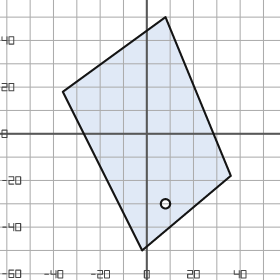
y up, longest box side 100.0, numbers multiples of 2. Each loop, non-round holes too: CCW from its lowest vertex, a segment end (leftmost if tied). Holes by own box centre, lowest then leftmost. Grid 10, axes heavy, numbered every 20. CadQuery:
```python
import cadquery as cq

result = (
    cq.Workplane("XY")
    .moveTo(-2.0, -50.0)
    .lineTo(36.0, -18.0)
    .lineTo(8.0, 50.0)
    .lineTo(-36.0, 18.0)
    .close()
    .moveTo(8.0, -30.0)
    .circle(2.0)
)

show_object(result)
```